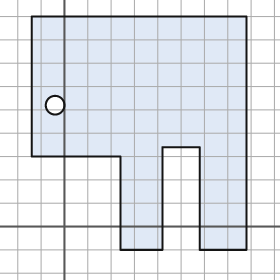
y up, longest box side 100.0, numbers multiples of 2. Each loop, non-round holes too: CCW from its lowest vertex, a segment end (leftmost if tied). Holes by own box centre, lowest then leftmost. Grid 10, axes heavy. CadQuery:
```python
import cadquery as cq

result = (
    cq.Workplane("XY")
    .moveTo(24.0, -10.0)
    .lineTo(42.0, -10.0)
    .lineTo(42.0, 34.0)
    .lineTo(58.0, 34.0)
    .lineTo(58.0, -10.0)
    .lineTo(78.0, -10.0)
    .lineTo(78.0, 90.0)
    .lineTo(-14.0, 90.0)
    .lineTo(-14.0, 30.0)
    .lineTo(24.0, 30.0)
    .close()
    .moveTo(-4.0, 52.0)
    .circle(4.0)
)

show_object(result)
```